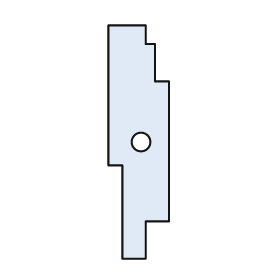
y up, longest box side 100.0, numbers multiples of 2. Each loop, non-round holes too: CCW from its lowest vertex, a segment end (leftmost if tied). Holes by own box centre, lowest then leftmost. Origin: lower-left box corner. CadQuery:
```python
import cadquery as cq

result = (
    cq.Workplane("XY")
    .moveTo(6.0, 0.0)
    .lineTo(16.0, 0.0)
    .lineTo(16.0, 16.0)
    .lineTo(26.0, 16.0)
    .lineTo(26.0, 76.0)
    .lineTo(20.0, 76.0)
    .lineTo(20.0, 92.0)
    .lineTo(16.0, 92.0)
    .lineTo(16.0, 100.0)
    .lineTo(0.0, 100.0)
    .lineTo(0.0, 40.0)
    .lineTo(6.0, 40.0)
    .close()
    .moveTo(14.0, 50.0)
    .circle(4.0)
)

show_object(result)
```